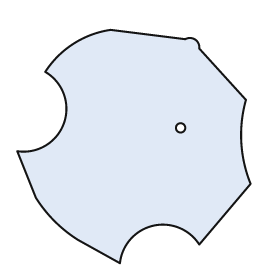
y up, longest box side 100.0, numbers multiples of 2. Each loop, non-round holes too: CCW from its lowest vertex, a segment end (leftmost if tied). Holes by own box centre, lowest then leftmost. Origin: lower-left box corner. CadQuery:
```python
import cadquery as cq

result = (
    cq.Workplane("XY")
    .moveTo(44.0, 0.0)
    .threePointArc((58.0, 16.0), (78.0, 8.0))
    .lineTo(100.0, 34.0)
    .threePointArc((96.0, 52.0), (98.0, 70.0))
    .lineTo(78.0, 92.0)
    .threePointArc((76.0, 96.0), (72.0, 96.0))
    .lineTo(40.0, 100.0)
    .threePointArc((24.0, 94.0), (12.0, 82.0))
    .threePointArc((20.0, 60.0), (0.0, 48.0))
    .lineTo(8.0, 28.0)
    .threePointArc((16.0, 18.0), (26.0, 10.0))
    .close()
    .moveTo(70.0, 58.0)
    .circle(2.0)
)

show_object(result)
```